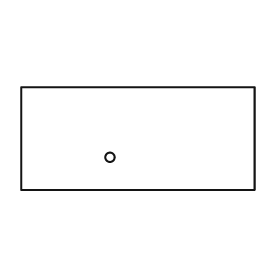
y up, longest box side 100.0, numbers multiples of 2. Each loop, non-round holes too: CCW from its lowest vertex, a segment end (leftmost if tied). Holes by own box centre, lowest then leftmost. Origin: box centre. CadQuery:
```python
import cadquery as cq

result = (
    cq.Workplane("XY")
    .moveTo(-50.0, -22.0)
    .lineTo(50.0, -22.0)
    .lineTo(50.0, 22.0)
    .lineTo(-50.0, 22.0)
    .close()
    .moveTo(-12.0, -8.0)
    .circle(2.0)
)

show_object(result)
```